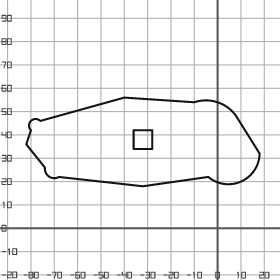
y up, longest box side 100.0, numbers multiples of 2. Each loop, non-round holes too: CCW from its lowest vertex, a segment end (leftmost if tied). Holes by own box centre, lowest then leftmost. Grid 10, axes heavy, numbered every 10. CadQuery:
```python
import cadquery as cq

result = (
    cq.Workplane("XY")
    .moveTo(-32.0, 18.0)
    .lineTo(-4.0, 22.0)
    .threePointArc((10.0, 20.0), (18.0, 32.0))
    .lineTo(8.0, 48.0)
    .threePointArc((0.0, 54.0), (-10.0, 54.0))
    .lineTo(-40.0, 56.0)
    .lineTo(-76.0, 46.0)
    .threePointArc((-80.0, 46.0), (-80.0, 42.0))
    .lineTo(-82.0, 36.0)
    .lineTo(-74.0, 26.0)
    .threePointArc((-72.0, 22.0), (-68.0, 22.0))
    .close()
    .moveTo(-36.0, 34.0)
    .lineTo(-28.0, 34.0)
    .lineTo(-28.0, 42.0)
    .lineTo(-36.0, 42.0)
    .close()
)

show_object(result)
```